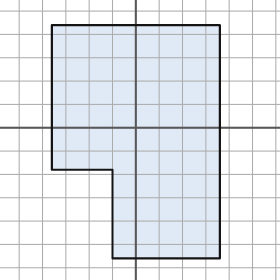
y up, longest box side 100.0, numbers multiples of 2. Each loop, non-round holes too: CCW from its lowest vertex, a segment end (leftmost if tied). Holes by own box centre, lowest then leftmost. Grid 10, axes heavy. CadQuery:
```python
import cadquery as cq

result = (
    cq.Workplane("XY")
    .moveTo(-10.0, -56.0)
    .lineTo(36.0, -56.0)
    .lineTo(36.0, 44.0)
    .lineTo(-36.0, 44.0)
    .lineTo(-36.0, -18.0)
    .lineTo(-10.0, -18.0)
    .close()
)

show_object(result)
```